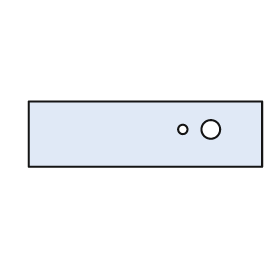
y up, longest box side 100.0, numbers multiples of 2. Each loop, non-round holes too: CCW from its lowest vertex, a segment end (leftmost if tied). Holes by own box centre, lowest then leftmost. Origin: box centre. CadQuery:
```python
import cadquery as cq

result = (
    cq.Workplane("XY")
    .moveTo(-50.0, -14.0)
    .lineTo(50.0, -14.0)
    .lineTo(50.0, 14.0)
    .lineTo(-50.0, 14.0)
    .close()
    .moveTo(16.0, 2.0)
    .circle(2.0)
    .moveTo(28.0, 2.0)
    .circle(4.0)
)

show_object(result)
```